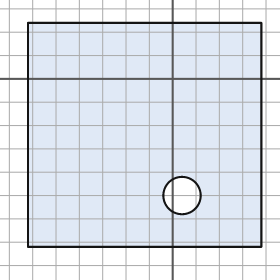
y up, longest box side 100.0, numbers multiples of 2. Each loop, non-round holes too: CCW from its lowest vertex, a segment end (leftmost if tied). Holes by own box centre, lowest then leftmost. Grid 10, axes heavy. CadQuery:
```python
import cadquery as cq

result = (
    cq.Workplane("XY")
    .moveTo(-62.0, -72.0)
    .lineTo(38.0, -72.0)
    .lineTo(38.0, 24.0)
    .lineTo(-62.0, 24.0)
    .close()
    .moveTo(4.0, -50.0)
    .circle(8.0)
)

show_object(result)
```